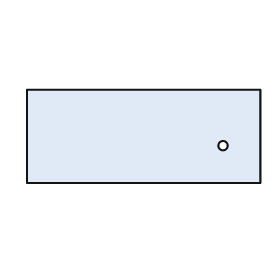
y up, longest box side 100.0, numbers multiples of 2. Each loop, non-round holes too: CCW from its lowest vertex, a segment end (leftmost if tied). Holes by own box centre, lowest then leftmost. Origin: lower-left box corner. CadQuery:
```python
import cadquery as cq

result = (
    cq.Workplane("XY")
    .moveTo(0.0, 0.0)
    .lineTo(100.0, 0.0)
    .lineTo(100.0, 40.0)
    .lineTo(0.0, 40.0)
    .close()
    .moveTo(84.0, 16.0)
    .circle(2.0)
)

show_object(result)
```